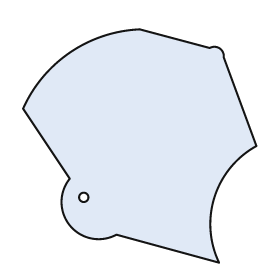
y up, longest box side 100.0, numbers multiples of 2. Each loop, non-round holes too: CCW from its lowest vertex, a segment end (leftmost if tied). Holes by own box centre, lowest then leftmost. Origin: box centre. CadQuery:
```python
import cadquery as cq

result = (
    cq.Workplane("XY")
    .moveTo(34.0, -50.0)
    .threePointArc((32.0, -22.0), (50.0, 0.0))
    .lineTo(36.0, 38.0)
    .threePointArc((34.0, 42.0), (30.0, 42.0))
    .lineTo(0.0, 50.0)
    .threePointArc((-30.0, 40.0), (-50.0, 16.0))
    .lineTo(-30.0, -14.0)
    .threePointArc((-30.0, -34.0), (-10.0, -38.0))
    .close()
    .moveTo(-24.0, -22.0)
    .circle(2.0)
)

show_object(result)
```